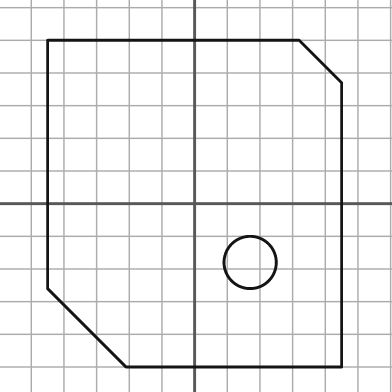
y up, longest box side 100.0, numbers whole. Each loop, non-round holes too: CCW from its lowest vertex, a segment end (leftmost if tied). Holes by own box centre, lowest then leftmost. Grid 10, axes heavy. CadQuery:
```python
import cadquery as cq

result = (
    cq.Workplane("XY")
    .moveTo(-21.0, -50.0)
    .lineTo(45.0, -50.0)
    .lineTo(45.0, 37.0)
    .lineTo(32.0, 50.0)
    .lineTo(-45.0, 50.0)
    .lineTo(-45.0, -26.0)
    .close()
    .moveTo(17.0, -18.0)
    .circle(8.0)
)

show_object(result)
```